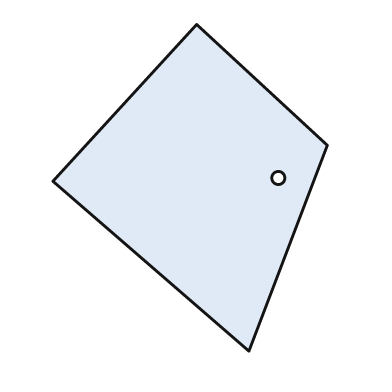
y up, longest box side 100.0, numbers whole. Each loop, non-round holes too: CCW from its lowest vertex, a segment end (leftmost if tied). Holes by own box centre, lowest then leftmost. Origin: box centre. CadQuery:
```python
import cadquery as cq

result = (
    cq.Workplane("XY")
    .moveTo(18.0, -50.0)
    .lineTo(42.0, 13.0)
    .lineTo(2.0, 50.0)
    .lineTo(-42.0, 2.0)
    .close()
    .moveTo(27.0, 3.0)
    .circle(2.0)
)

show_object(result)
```